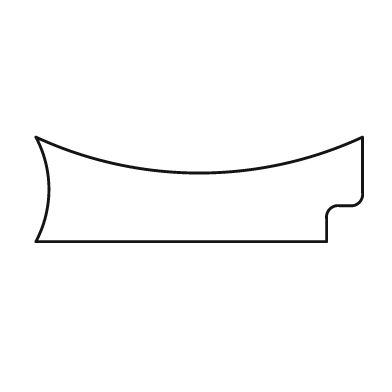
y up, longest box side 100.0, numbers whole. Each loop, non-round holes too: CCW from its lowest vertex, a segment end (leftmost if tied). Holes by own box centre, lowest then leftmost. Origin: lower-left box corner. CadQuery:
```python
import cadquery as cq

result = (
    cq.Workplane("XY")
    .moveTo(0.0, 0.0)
    .lineTo(89.0, 0.0)
    .lineTo(89.0, 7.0)
    .threePointArc((90.0, 10.0), (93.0, 11.0))
    .lineTo(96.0, 11.0)
    .threePointArc((99.0, 12.0), (100.0, 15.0))
    .lineTo(100.0, 32.0)
    .threePointArc((50.0, 21.0), (0.0, 32.0))
    .threePointArc((4.0, 16.0), (0.0, 0.0))
    .close()
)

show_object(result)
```